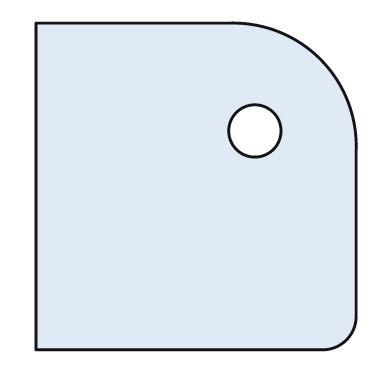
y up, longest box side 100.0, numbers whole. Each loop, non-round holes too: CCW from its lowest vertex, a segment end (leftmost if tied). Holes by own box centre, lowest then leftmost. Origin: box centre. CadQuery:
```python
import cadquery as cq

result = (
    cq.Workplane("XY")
    .moveTo(-49.0, -50.0)
    .lineTo(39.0, -50.0)
    .threePointArc((46.0, -47.0), (49.0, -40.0))
    .lineTo(49.0, 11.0)
    .threePointArc((38.0, 39.0), (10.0, 50.0))
    .lineTo(-49.0, 50.0)
    .close()
    .moveTo(18.0, 17.0)
    .circle(8.0)
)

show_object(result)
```